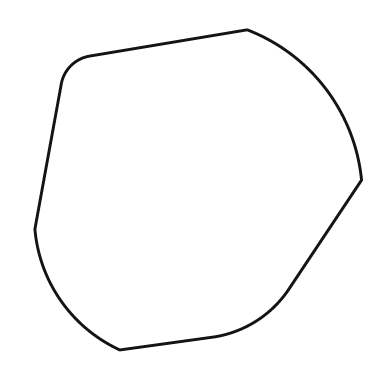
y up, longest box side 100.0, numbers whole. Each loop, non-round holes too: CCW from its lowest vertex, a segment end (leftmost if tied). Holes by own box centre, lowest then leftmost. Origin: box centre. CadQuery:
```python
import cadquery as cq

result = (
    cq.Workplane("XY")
    .moveTo(-24.0, -49.0)
    .lineTo(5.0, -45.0)
    .threePointArc((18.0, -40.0), (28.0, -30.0))
    .lineTo(50.0, 3.0)
    .threePointArc((39.0, 31.0), (15.0, 49.0))
    .lineTo(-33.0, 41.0)
    .threePointArc((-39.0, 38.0), (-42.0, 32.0))
    .lineTo(-50.0, -12.0)
    .threePointArc((-42.0, -34.0), (-24.0, -49.0))
    .close()
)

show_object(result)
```